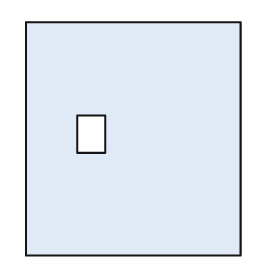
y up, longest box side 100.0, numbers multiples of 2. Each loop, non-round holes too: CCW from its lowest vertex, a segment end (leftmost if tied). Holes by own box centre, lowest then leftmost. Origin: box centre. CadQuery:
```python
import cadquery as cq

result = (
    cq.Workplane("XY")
    .moveTo(-46.0, -50.0)
    .lineTo(46.0, -50.0)
    .lineTo(46.0, 50.0)
    .lineTo(-46.0, 50.0)
    .close()
    .moveTo(-24.0, -6.0)
    .lineTo(-12.0, -6.0)
    .lineTo(-12.0, 10.0)
    .lineTo(-24.0, 10.0)
    .close()
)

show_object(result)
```